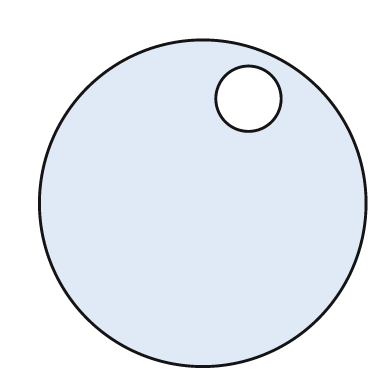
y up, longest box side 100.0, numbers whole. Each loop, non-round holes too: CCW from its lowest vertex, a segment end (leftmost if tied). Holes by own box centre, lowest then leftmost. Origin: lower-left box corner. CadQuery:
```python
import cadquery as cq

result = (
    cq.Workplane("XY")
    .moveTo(50.0, 50.0)
    .circle(50.0)
    .moveTo(64.0, 82.0)
    .circle(10.0)
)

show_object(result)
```